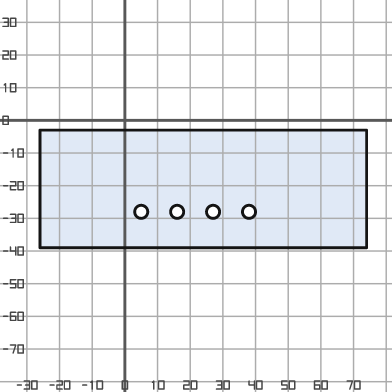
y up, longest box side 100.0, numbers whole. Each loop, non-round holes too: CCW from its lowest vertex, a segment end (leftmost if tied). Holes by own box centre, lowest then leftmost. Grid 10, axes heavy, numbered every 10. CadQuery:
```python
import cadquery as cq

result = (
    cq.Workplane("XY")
    .moveTo(-26.0, -39.0)
    .lineTo(74.0, -39.0)
    .lineTo(74.0, -3.0)
    .lineTo(-26.0, -3.0)
    .close()
    .moveTo(5.0, -28.0)
    .circle(2.0)
    .moveTo(16.0, -28.0)
    .circle(2.0)
    .moveTo(27.0, -28.0)
    .circle(2.0)
    .moveTo(38.0, -28.0)
    .circle(2.0)
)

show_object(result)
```